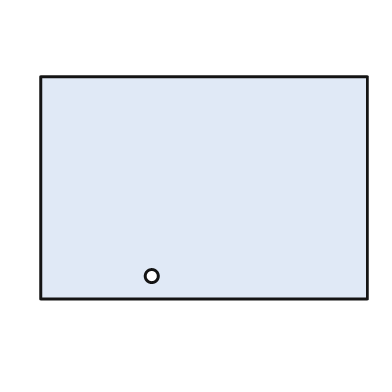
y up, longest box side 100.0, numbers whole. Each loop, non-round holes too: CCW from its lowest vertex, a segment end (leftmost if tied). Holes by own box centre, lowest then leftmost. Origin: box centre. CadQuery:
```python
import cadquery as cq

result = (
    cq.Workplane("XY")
    .moveTo(-50.0, -34.0)
    .lineTo(50.0, -34.0)
    .lineTo(50.0, 34.0)
    .lineTo(-50.0, 34.0)
    .close()
    .moveTo(-16.0, -27.0)
    .circle(2.0)
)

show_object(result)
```